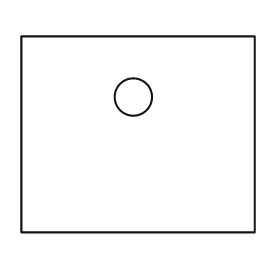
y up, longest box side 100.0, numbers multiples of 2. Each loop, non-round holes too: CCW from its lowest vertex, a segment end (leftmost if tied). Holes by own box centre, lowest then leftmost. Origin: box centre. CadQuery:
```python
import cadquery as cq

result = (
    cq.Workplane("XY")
    .moveTo(-50.0, -42.0)
    .lineTo(50.0, -42.0)
    .lineTo(50.0, 42.0)
    .lineTo(-50.0, 42.0)
    .close()
    .moveTo(-2.0, 16.0)
    .circle(8.0)
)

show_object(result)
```